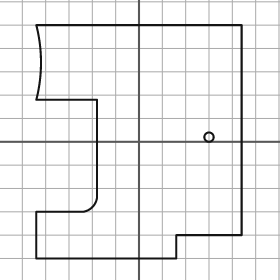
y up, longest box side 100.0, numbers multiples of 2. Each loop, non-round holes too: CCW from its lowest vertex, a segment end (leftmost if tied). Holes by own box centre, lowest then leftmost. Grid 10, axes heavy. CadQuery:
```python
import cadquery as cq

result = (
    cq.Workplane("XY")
    .moveTo(-44.0, -50.0)
    .lineTo(16.0, -50.0)
    .lineTo(16.0, -40.0)
    .lineTo(44.0, -40.0)
    .lineTo(44.0, 50.0)
    .lineTo(-44.0, 50.0)
    .threePointArc((-42.0, 34.0), (-44.0, 18.0))
    .lineTo(-18.0, 18.0)
    .lineTo(-18.0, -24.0)
    .threePointArc((-20.0, -28.0), (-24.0, -30.0))
    .lineTo(-44.0, -30.0)
    .close()
    .moveTo(30.0, 2.0)
    .circle(2.0)
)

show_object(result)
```